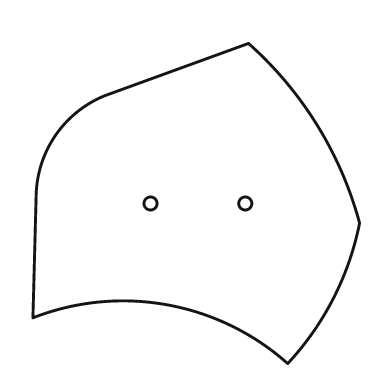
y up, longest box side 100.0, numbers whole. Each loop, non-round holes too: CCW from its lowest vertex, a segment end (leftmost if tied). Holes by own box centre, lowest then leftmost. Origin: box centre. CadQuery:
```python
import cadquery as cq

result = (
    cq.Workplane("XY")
    .moveTo(28.0, -49.0)
    .threePointArc((42.0, -29.0), (50.0, -6.0))
    .threePointArc((37.0, 24.0), (16.0, 49.0))
    .lineTo(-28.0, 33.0)
    .threePointArc((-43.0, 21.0), (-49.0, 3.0))
    .lineTo(-50.0, -35.0)
    .threePointArc((-9.0, -31.0), (28.0, -49.0))
    .close()
    .moveTo(-14.0, 0.0)
    .circle(2.0)
    .moveTo(15.0, 0.0)
    .circle(2.0)
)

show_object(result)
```